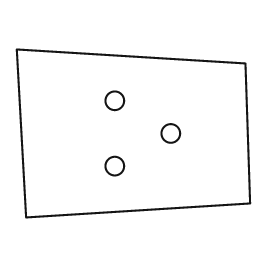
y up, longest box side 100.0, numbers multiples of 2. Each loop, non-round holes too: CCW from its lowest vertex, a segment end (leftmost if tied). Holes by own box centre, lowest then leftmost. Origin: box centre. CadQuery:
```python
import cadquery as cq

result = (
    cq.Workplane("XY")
    .moveTo(-46.0, -36.0)
    .lineTo(50.0, -30.0)
    .lineTo(48.0, 30.0)
    .lineTo(-50.0, 36.0)
    .close()
    .moveTo(-8.0, -14.0)
    .circle(4.0)
    .moveTo(16.0, 0.0)
    .circle(4.0)
    .moveTo(-8.0, 14.0)
    .circle(4.0)
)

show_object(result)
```